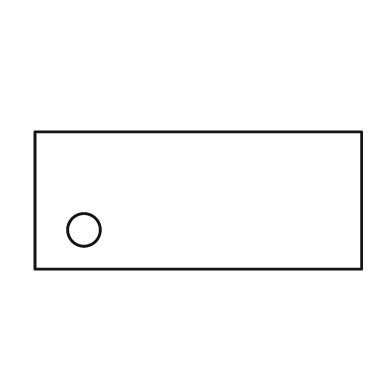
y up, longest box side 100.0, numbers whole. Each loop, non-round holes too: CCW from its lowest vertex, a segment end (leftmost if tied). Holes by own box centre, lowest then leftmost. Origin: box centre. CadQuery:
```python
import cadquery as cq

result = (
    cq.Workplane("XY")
    .moveTo(-50.0, -21.0)
    .lineTo(50.0, -21.0)
    .lineTo(50.0, 21.0)
    .lineTo(-50.0, 21.0)
    .close()
    .moveTo(-35.0, -9.0)
    .circle(5.0)
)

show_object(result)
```